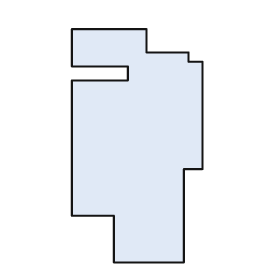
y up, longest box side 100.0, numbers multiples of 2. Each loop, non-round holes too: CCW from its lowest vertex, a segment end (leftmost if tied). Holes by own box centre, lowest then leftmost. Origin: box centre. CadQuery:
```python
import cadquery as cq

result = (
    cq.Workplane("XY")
    .moveTo(-10.0, -50.0)
    .lineTo(20.0, -50.0)
    .lineTo(20.0, -10.0)
    .lineTo(28.0, -10.0)
    .lineTo(28.0, 36.0)
    .lineTo(22.0, 36.0)
    .lineTo(22.0, 40.0)
    .lineTo(4.0, 40.0)
    .lineTo(4.0, 50.0)
    .lineTo(-28.0, 50.0)
    .lineTo(-28.0, 34.0)
    .lineTo(-4.0, 34.0)
    .lineTo(-4.0, 28.0)
    .lineTo(-28.0, 28.0)
    .lineTo(-28.0, -30.0)
    .lineTo(-10.0, -30.0)
    .close()
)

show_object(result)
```